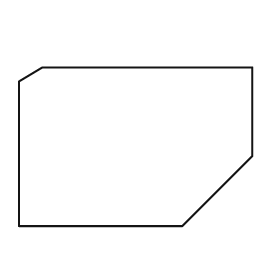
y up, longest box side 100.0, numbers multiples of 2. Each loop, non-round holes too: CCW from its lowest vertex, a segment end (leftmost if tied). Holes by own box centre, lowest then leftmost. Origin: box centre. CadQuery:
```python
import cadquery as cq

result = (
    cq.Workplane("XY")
    .moveTo(-50.0, -34.0)
    .lineTo(20.0, -34.0)
    .lineTo(50.0, -4.0)
    .lineTo(50.0, 34.0)
    .lineTo(-40.0, 34.0)
    .lineTo(-50.0, 28.0)
    .close()
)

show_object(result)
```